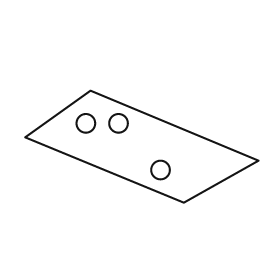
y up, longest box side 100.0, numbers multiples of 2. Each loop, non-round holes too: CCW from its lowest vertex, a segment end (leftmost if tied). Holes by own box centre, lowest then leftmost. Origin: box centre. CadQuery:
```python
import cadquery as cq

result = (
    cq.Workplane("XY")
    .moveTo(18.0, -24.0)
    .lineTo(50.0, -6.0)
    .lineTo(-22.0, 24.0)
    .lineTo(-50.0, 4.0)
    .close()
    .moveTo(8.0, -10.0)
    .circle(4.0)
    .moveTo(-24.0, 10.0)
    .circle(4.0)
    .moveTo(-10.0, 10.0)
    .circle(4.0)
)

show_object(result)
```